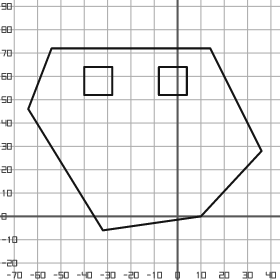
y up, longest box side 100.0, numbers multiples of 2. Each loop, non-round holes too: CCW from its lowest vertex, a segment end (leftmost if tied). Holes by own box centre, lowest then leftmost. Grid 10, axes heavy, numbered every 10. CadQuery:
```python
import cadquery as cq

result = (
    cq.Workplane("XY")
    .moveTo(-32.0, -6.0)
    .lineTo(10.0, 0.0)
    .lineTo(36.0, 28.0)
    .lineTo(14.0, 72.0)
    .lineTo(-54.0, 72.0)
    .lineTo(-64.0, 46.0)
    .close()
    .moveTo(-40.0, 52.0)
    .lineTo(-28.0, 52.0)
    .lineTo(-28.0, 64.0)
    .lineTo(-40.0, 64.0)
    .close()
    .moveTo(-8.0, 52.0)
    .lineTo(4.0, 52.0)
    .lineTo(4.0, 64.0)
    .lineTo(-8.0, 64.0)
    .close()
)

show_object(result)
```